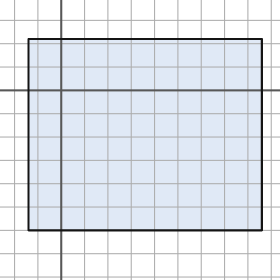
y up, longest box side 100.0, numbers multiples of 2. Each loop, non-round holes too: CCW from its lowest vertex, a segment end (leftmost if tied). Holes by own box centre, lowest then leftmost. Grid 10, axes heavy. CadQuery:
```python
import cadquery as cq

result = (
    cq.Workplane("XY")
    .moveTo(-14.0, -60.0)
    .lineTo(86.0, -60.0)
    .lineTo(86.0, 22.0)
    .lineTo(-14.0, 22.0)
    .close()
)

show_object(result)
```